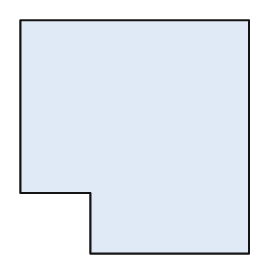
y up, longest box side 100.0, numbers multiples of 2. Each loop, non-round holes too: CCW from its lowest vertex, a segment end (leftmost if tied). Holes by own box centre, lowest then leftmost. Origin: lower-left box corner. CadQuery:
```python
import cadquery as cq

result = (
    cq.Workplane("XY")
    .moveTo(30.0, 0.0)
    .lineTo(98.0, 0.0)
    .lineTo(98.0, 100.0)
    .lineTo(0.0, 100.0)
    .lineTo(0.0, 26.0)
    .lineTo(30.0, 26.0)
    .close()
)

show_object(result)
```